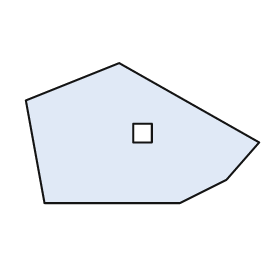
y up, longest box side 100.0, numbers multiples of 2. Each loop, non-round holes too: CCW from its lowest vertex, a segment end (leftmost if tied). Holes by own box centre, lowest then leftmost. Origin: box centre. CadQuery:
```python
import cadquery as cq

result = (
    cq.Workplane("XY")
    .moveTo(-42.0, -30.0)
    .lineTo(16.0, -30.0)
    .lineTo(36.0, -20.0)
    .lineTo(50.0, -4.0)
    .lineTo(-10.0, 30.0)
    .lineTo(-50.0, 14.0)
    .close()
    .moveTo(-4.0, -4.0)
    .lineTo(4.0, -4.0)
    .lineTo(4.0, 4.0)
    .lineTo(-4.0, 4.0)
    .close()
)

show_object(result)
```